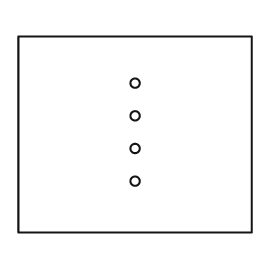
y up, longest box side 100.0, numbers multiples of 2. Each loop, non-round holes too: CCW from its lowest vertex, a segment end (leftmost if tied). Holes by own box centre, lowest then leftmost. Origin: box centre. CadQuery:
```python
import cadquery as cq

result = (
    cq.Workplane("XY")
    .moveTo(-50.0, -42.0)
    .lineTo(50.0, -42.0)
    .lineTo(50.0, 42.0)
    .lineTo(-50.0, 42.0)
    .close()
    .moveTo(0.0, -20.0)
    .circle(2.0)
    .moveTo(0.0, -6.0)
    .circle(2.0)
    .moveTo(0.0, 8.0)
    .circle(2.0)
    .moveTo(0.0, 22.0)
    .circle(2.0)
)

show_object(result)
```